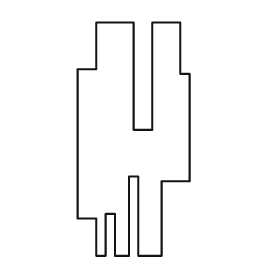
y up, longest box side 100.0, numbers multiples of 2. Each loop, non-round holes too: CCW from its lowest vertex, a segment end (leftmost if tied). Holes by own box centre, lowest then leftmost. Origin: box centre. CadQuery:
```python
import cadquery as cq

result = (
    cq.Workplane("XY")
    .moveTo(-16.0, -50.0)
    .lineTo(-12.0, -50.0)
    .lineTo(-12.0, -32.0)
    .lineTo(-8.0, -32.0)
    .lineTo(-8.0, -50.0)
    .lineTo(-2.0, -50.0)
    .lineTo(-2.0, -16.0)
    .lineTo(2.0, -16.0)
    .lineTo(2.0, -50.0)
    .lineTo(12.0, -50.0)
    .lineTo(12.0, -18.0)
    .lineTo(24.0, -18.0)
    .lineTo(24.0, 28.0)
    .lineTo(20.0, 28.0)
    .lineTo(20.0, 50.0)
    .lineTo(8.0, 50.0)
    .lineTo(8.0, 4.0)
    .lineTo(0.0, 4.0)
    .lineTo(0.0, 50.0)
    .lineTo(-16.0, 50.0)
    .lineTo(-16.0, 30.0)
    .lineTo(-24.0, 30.0)
    .lineTo(-24.0, -34.0)
    .lineTo(-16.0, -34.0)
    .close()
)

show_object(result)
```